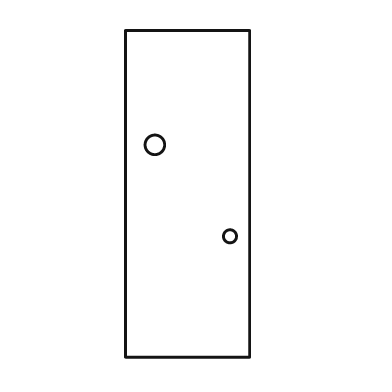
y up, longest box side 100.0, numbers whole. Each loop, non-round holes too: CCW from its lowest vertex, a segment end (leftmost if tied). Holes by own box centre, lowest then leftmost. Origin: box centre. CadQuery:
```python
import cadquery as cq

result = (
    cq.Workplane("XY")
    .moveTo(-19.0, -50.0)
    .lineTo(19.0, -50.0)
    .lineTo(19.0, 50.0)
    .lineTo(-19.0, 50.0)
    .close()
    .moveTo(13.0, -13.0)
    .circle(2.0)
    .moveTo(-10.0, 15.0)
    .circle(3.0)
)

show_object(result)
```